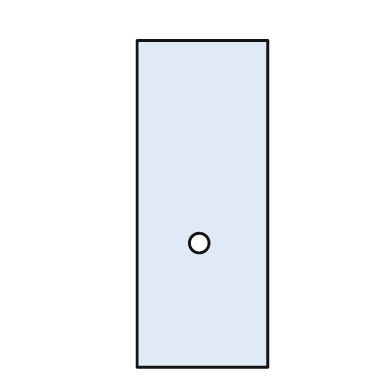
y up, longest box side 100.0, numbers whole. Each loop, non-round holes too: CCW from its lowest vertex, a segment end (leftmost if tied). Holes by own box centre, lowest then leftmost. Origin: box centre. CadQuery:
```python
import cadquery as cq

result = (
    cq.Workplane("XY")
    .moveTo(-20.0, -50.0)
    .lineTo(20.0, -50.0)
    .lineTo(20.0, 50.0)
    .lineTo(-20.0, 50.0)
    .close()
    .moveTo(-1.0, -12.0)
    .circle(3.0)
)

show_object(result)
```